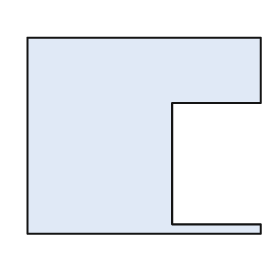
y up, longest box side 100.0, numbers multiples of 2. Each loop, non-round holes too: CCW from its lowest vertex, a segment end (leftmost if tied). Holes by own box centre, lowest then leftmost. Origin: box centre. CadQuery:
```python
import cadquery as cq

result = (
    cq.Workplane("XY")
    .moveTo(-50.0, -42.0)
    .lineTo(50.0, -42.0)
    .lineTo(50.0, -38.0)
    .lineTo(12.0, -38.0)
    .lineTo(12.0, 14.0)
    .lineTo(50.0, 14.0)
    .lineTo(50.0, 42.0)
    .lineTo(-50.0, 42.0)
    .close()
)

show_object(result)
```